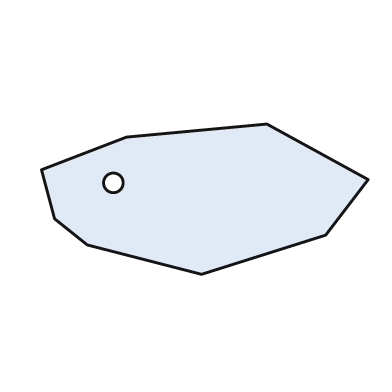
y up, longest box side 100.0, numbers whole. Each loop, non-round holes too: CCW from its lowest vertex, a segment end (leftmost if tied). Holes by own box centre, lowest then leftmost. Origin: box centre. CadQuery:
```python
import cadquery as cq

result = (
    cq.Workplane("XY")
    .moveTo(-1.0, -23.0)
    .lineTo(37.0, -11.0)
    .lineTo(50.0, 6.0)
    .lineTo(19.0, 23.0)
    .lineTo(-24.0, 19.0)
    .lineTo(-50.0, 9.0)
    .lineTo(-46.0, -6.0)
    .lineTo(-36.0, -14.0)
    .close()
    .moveTo(-28.0, 5.0)
    .circle(3.0)
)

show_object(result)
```